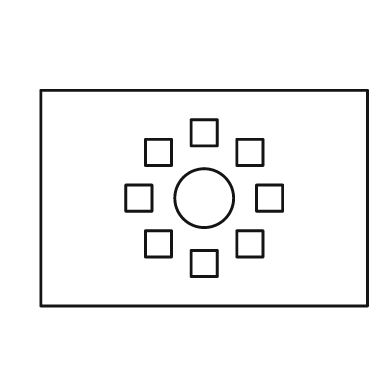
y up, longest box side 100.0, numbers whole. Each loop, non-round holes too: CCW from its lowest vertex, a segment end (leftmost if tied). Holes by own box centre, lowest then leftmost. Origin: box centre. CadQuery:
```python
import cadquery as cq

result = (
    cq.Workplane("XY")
    .moveTo(-50.0, -33.0)
    .lineTo(50.0, -33.0)
    .lineTo(50.0, 33.0)
    .lineTo(-50.0, 33.0)
    .close()
    .moveTo(-4.0, -24.0)
    .lineTo(4.0, -24.0)
    .lineTo(4.0, -16.0)
    .lineTo(-4.0, -16.0)
    .close()
    .moveTo(-18.0, -18.0)
    .lineTo(-10.0, -18.0)
    .lineTo(-10.0, -10.0)
    .lineTo(-18.0, -10.0)
    .close()
    .moveTo(10.0, -18.0)
    .lineTo(18.0, -18.0)
    .lineTo(18.0, -10.0)
    .lineTo(10.0, -10.0)
    .close()
    .moveTo(-24.0, -4.0)
    .lineTo(-16.0, -4.0)
    .lineTo(-16.0, 4.0)
    .lineTo(-24.0, 4.0)
    .close()
    .moveTo(0.0, 0.0)
    .circle(9.0)
    .moveTo(16.0, -4.0)
    .lineTo(24.0, -4.0)
    .lineTo(24.0, 4.0)
    .lineTo(16.0, 4.0)
    .close()
    .moveTo(-18.0, 10.0)
    .lineTo(-10.0, 10.0)
    .lineTo(-10.0, 18.0)
    .lineTo(-18.0, 18.0)
    .close()
    .moveTo(10.0, 10.0)
    .lineTo(18.0, 10.0)
    .lineTo(18.0, 18.0)
    .lineTo(10.0, 18.0)
    .close()
    .moveTo(-4.0, 16.0)
    .lineTo(4.0, 16.0)
    .lineTo(4.0, 24.0)
    .lineTo(-4.0, 24.0)
    .close()
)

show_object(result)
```